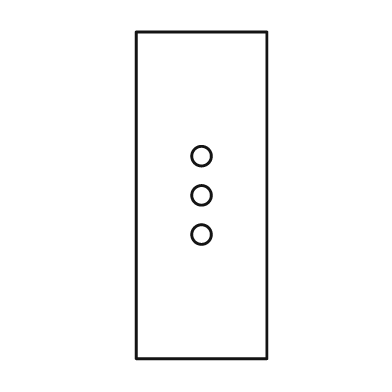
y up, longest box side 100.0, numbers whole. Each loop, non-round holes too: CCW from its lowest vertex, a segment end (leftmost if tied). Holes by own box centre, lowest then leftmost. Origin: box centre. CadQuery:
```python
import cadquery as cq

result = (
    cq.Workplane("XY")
    .moveTo(-20.0, -50.0)
    .lineTo(20.0, -50.0)
    .lineTo(20.0, 50.0)
    .lineTo(-20.0, 50.0)
    .close()
    .moveTo(0.0, -12.0)
    .circle(3.0)
    .moveTo(0.0, 0.0)
    .circle(3.0)
    .moveTo(0.0, 12.0)
    .circle(3.0)
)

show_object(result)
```